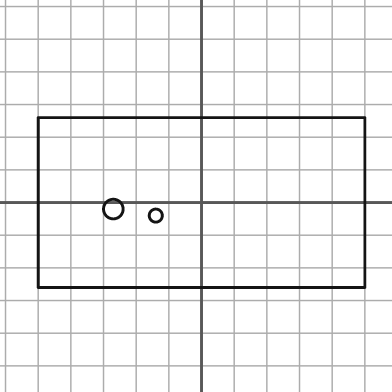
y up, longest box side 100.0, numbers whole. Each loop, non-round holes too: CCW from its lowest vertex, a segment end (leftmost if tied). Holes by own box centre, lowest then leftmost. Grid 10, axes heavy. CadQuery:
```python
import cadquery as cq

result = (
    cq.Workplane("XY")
    .moveTo(-50.0, -26.0)
    .lineTo(50.0, -26.0)
    .lineTo(50.0, 26.0)
    .lineTo(-50.0, 26.0)
    .close()
    .moveTo(-14.0, -4.0)
    .circle(2.0)
    .moveTo(-27.0, -2.0)
    .circle(3.0)
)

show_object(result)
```